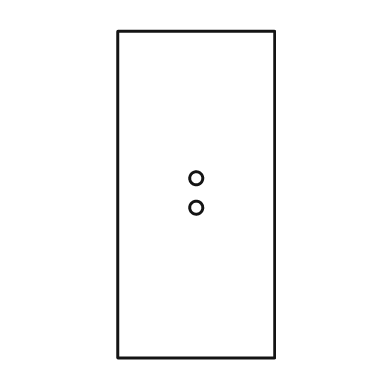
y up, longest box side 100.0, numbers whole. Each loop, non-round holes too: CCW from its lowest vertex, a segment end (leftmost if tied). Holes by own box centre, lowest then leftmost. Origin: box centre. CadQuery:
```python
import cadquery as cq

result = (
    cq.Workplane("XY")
    .moveTo(-24.0, -50.0)
    .lineTo(24.0, -50.0)
    .lineTo(24.0, 50.0)
    .lineTo(-24.0, 50.0)
    .close()
    .moveTo(0.0, -4.0)
    .circle(2.0)
    .moveTo(0.0, 5.0)
    .circle(2.0)
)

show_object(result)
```